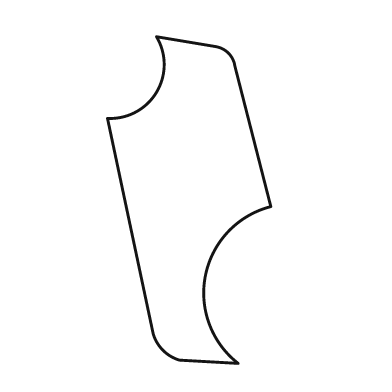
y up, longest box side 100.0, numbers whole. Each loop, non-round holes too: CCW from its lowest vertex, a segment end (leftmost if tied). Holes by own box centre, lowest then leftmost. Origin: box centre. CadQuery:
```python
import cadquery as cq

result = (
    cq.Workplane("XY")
    .moveTo(15.0, -50.0)
    .threePointArc((5.0, -23.0), (25.0, -2.0))
    .lineTo(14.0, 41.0)
    .threePointArc((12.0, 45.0), (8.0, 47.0))
    .lineTo(-10.0, 50.0)
    .threePointArc((-10.0, 33.0), (-25.0, 25.0))
    .lineTo(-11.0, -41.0)
    .threePointArc((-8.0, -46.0), (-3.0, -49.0))
    .close()
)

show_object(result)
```